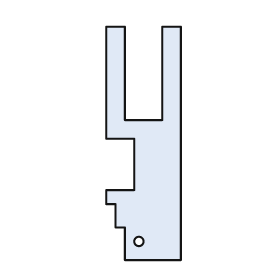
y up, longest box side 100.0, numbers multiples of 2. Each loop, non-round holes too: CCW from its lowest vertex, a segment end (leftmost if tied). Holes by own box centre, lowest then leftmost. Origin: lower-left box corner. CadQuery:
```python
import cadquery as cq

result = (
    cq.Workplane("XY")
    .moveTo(8.0, 0.0)
    .lineTo(32.0, 0.0)
    .lineTo(32.0, 100.0)
    .lineTo(24.0, 100.0)
    .lineTo(24.0, 60.0)
    .lineTo(8.0, 60.0)
    .lineTo(8.0, 100.0)
    .lineTo(0.0, 100.0)
    .lineTo(0.0, 52.0)
    .lineTo(12.0, 52.0)
    .lineTo(12.0, 30.0)
    .lineTo(0.0, 30.0)
    .lineTo(0.0, 24.0)
    .lineTo(4.0, 24.0)
    .lineTo(4.0, 14.0)
    .lineTo(8.0, 14.0)
    .close()
    .moveTo(14.0, 8.0)
    .circle(2.0)
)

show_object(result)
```